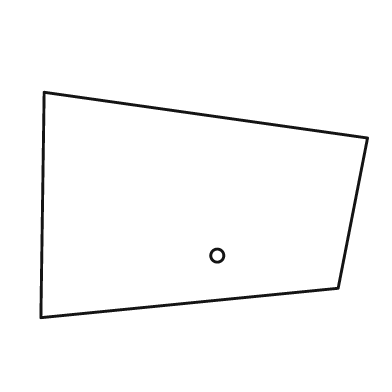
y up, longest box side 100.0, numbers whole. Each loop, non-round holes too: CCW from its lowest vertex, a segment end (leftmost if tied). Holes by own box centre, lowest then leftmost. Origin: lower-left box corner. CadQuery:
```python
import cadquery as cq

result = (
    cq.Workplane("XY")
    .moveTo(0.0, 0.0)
    .lineTo(91.0, 9.0)
    .lineTo(100.0, 55.0)
    .lineTo(1.0, 69.0)
    .close()
    .moveTo(54.0, 19.0)
    .circle(2.0)
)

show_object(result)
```